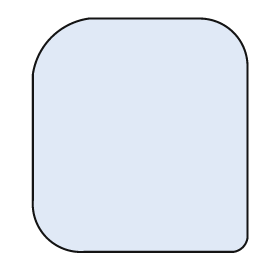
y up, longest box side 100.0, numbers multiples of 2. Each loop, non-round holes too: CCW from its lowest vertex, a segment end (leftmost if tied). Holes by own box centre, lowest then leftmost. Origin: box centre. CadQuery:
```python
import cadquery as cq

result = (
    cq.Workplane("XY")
    .moveTo(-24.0, -50.0)
    .lineTo(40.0, -50.0)
    .threePointArc((44.0, -48.0), (46.0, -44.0))
    .lineTo(46.0, 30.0)
    .threePointArc((40.0, 44.0), (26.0, 50.0))
    .lineTo(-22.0, 50.0)
    .threePointArc((-38.0, 42.0), (-46.0, 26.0))
    .lineTo(-46.0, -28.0)
    .threePointArc((-40.0, -44.0), (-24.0, -50.0))
    .close()
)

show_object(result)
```